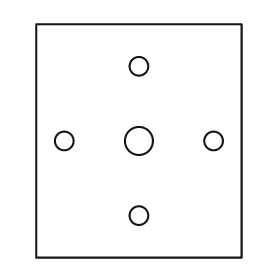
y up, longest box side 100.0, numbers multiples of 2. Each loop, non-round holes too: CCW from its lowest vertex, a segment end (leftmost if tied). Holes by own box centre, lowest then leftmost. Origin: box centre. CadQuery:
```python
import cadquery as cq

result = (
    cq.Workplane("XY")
    .moveTo(-44.0, -50.0)
    .lineTo(44.0, -50.0)
    .lineTo(44.0, 50.0)
    .lineTo(-44.0, 50.0)
    .close()
    .moveTo(0.0, -32.0)
    .circle(4.0)
    .moveTo(-32.0, 0.0)
    .circle(4.0)
    .moveTo(0.0, 0.0)
    .circle(6.0)
    .moveTo(32.0, 0.0)
    .circle(4.0)
    .moveTo(0.0, 32.0)
    .circle(4.0)
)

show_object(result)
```